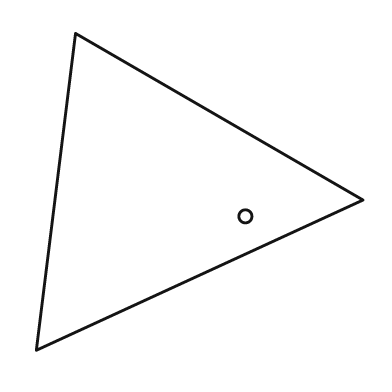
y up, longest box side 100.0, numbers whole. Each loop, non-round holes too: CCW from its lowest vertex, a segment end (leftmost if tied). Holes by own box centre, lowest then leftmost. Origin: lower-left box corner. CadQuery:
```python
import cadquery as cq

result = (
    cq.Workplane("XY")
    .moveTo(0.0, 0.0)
    .lineTo(100.0, 46.0)
    .lineTo(12.0, 97.0)
    .close()
    .moveTo(64.0, 41.0)
    .circle(2.0)
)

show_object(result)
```